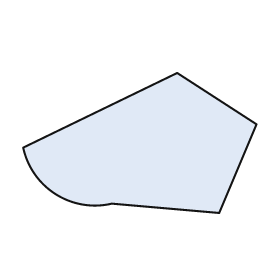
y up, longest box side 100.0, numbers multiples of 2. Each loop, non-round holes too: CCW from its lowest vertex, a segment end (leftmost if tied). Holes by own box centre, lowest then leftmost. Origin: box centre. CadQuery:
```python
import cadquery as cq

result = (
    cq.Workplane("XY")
    .moveTo(34.0, -30.0)
    .lineTo(50.0, 8.0)
    .lineTo(16.0, 30.0)
    .lineTo(-50.0, -2.0)
    .threePointArc((-36.0, -22.0), (-12.0, -26.0))
    .close()
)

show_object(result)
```